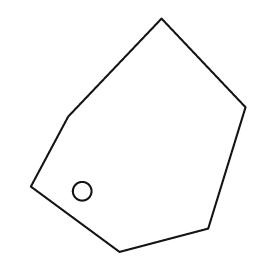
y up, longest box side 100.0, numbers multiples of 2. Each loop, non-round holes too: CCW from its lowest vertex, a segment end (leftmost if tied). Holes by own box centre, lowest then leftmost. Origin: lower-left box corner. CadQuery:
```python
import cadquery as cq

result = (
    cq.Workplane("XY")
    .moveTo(38.0, 0.0)
    .lineTo(76.0, 10.0)
    .lineTo(92.0, 62.0)
    .lineTo(56.0, 100.0)
    .lineTo(16.0, 58.0)
    .lineTo(0.0, 28.0)
    .close()
    .moveTo(22.0, 26.0)
    .circle(4.0)
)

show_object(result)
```